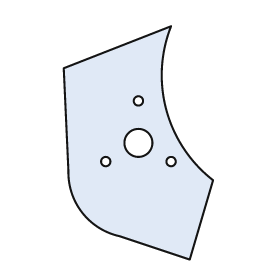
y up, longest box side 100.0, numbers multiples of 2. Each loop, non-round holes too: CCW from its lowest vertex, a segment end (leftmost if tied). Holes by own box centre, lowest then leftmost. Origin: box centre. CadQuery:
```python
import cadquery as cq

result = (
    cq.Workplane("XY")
    .moveTo(22.0, -50.0)
    .lineTo(32.0, -16.0)
    .threePointArc((12.0, 14.0), (14.0, 50.0))
    .lineTo(-32.0, 32.0)
    .lineTo(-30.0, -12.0)
    .threePointArc((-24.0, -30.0), (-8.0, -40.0))
    .close()
    .moveTo(-14.0, -8.0)
    .circle(2.0)
    .moveTo(14.0, -8.0)
    .circle(2.0)
    .moveTo(0.0, 0.0)
    .circle(6.0)
    .moveTo(0.0, 18.0)
    .circle(2.0)
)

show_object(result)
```